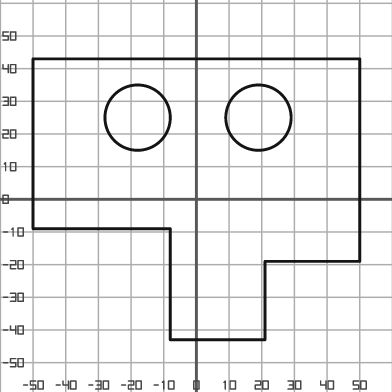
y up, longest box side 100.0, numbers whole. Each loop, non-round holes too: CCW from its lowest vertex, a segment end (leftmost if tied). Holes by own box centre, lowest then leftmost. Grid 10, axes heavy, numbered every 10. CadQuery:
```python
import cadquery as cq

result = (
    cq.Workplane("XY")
    .moveTo(-8.0, -43.0)
    .lineTo(21.0, -43.0)
    .lineTo(21.0, -19.0)
    .lineTo(50.0, -19.0)
    .lineTo(50.0, 43.0)
    .lineTo(-50.0, 43.0)
    .lineTo(-50.0, -9.0)
    .lineTo(-8.0, -9.0)
    .close()
    .moveTo(-18.0, 25.0)
    .circle(10.0)
    .moveTo(19.0, 25.0)
    .circle(10.0)
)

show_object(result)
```